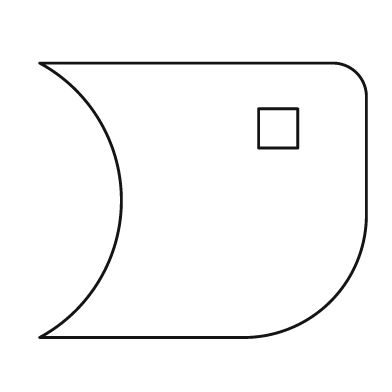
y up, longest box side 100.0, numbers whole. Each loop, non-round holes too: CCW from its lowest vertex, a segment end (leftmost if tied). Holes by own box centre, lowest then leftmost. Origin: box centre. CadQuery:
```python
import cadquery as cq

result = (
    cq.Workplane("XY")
    .moveTo(-50.0, -42.0)
    .lineTo(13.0, -42.0)
    .threePointArc((39.0, -31.0), (50.0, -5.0))
    .lineTo(50.0, 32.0)
    .threePointArc((47.0, 39.0), (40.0, 42.0))
    .lineTo(-50.0, 42.0)
    .threePointArc((-25.0, 0.0), (-50.0, -42.0))
    .close()
    .moveTo(17.0, 16.0)
    .lineTo(29.0, 16.0)
    .lineTo(29.0, 28.0)
    .lineTo(17.0, 28.0)
    .close()
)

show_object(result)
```